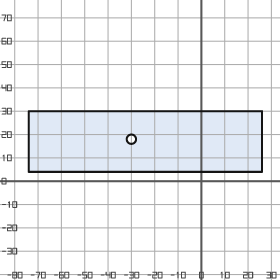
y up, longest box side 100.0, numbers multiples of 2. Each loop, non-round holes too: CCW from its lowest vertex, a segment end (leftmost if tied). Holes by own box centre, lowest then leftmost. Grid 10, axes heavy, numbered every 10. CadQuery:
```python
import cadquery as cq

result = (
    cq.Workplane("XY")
    .moveTo(-74.0, 4.0)
    .lineTo(26.0, 4.0)
    .lineTo(26.0, 30.0)
    .lineTo(-74.0, 30.0)
    .close()
    .moveTo(-30.0, 18.0)
    .circle(2.0)
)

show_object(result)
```